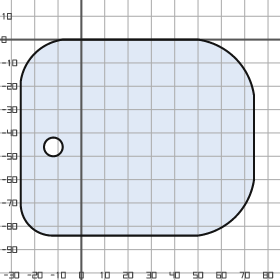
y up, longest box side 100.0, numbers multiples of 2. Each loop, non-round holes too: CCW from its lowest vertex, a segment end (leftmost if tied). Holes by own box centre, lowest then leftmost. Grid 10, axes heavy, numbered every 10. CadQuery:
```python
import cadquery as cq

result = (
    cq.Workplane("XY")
    .moveTo(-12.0, -84.0)
    .lineTo(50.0, -84.0)
    .threePointArc((66.0, -76.0), (74.0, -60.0))
    .lineTo(74.0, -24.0)
    .threePointArc((66.0, -8.0), (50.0, 0.0))
    .lineTo(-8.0, 0.0)
    .threePointArc((-20.0, -6.0), (-26.0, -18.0))
    .lineTo(-26.0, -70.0)
    .threePointArc((-22.0, -80.0), (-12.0, -84.0))
    .close()
    .moveTo(-12.0, -46.0)
    .circle(4.0)
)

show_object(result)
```